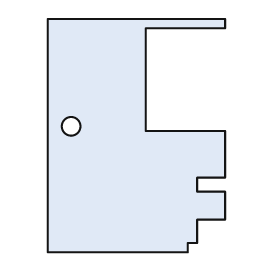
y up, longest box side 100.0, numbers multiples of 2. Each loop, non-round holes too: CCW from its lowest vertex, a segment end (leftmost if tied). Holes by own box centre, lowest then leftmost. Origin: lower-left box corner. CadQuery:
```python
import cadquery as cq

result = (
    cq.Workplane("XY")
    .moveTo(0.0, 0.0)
    .lineTo(60.0, 0.0)
    .lineTo(60.0, 4.0)
    .lineTo(64.0, 4.0)
    .lineTo(64.0, 14.0)
    .lineTo(76.0, 14.0)
    .lineTo(76.0, 26.0)
    .lineTo(64.0, 26.0)
    .lineTo(64.0, 32.0)
    .lineTo(76.0, 32.0)
    .lineTo(76.0, 52.0)
    .lineTo(42.0, 52.0)
    .lineTo(42.0, 96.0)
    .lineTo(76.0, 96.0)
    .lineTo(76.0, 100.0)
    .lineTo(0.0, 100.0)
    .close()
    .moveTo(10.0, 54.0)
    .circle(4.0)
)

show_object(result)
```